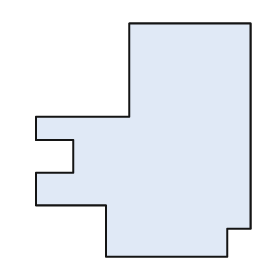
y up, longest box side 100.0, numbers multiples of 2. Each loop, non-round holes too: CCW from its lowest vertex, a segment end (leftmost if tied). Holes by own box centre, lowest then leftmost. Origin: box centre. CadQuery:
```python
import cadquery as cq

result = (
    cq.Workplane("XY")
    .moveTo(-16.0, -50.0)
    .lineTo(36.0, -50.0)
    .lineTo(36.0, -38.0)
    .lineTo(46.0, -38.0)
    .lineTo(46.0, 50.0)
    .lineTo(-6.0, 50.0)
    .lineTo(-6.0, 10.0)
    .lineTo(-46.0, 10.0)
    .lineTo(-46.0, 0.0)
    .lineTo(-30.0, 0.0)
    .lineTo(-30.0, -14.0)
    .lineTo(-46.0, -14.0)
    .lineTo(-46.0, -28.0)
    .lineTo(-16.0, -28.0)
    .close()
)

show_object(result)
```